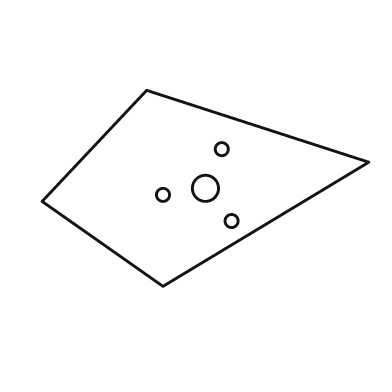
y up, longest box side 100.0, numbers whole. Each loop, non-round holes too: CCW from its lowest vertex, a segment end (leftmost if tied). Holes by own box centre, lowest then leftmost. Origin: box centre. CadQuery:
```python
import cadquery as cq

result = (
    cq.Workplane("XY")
    .moveTo(-13.0, -30.0)
    .lineTo(50.0, 8.0)
    .lineTo(-18.0, 30.0)
    .lineTo(-50.0, -4.0)
    .close()
    .moveTo(8.0, -10.0)
    .circle(2.0)
    .moveTo(-13.0, -2.0)
    .circle(2.0)
    .moveTo(0.0, 0.0)
    .circle(4.0)
    .moveTo(5.0, 12.0)
    .circle(2.0)
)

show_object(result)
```